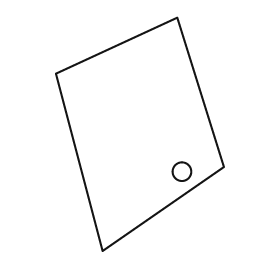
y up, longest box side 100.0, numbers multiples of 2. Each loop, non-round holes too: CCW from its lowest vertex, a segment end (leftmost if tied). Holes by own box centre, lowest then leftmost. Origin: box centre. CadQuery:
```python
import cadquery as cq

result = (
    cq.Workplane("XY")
    .moveTo(-16.0, -50.0)
    .lineTo(36.0, -14.0)
    .lineTo(16.0, 50.0)
    .lineTo(-36.0, 26.0)
    .close()
    .moveTo(18.0, -16.0)
    .circle(4.0)
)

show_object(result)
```